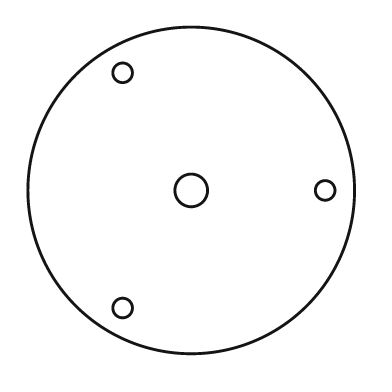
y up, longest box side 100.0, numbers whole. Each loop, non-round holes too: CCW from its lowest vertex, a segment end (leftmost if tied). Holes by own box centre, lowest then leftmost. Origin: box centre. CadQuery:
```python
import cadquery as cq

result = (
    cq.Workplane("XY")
    .moveTo(0.0, 0.0)
    .circle(50.0)
    .moveTo(-21.0, -36.0)
    .circle(3.0)
    .moveTo(0.0, 0.0)
    .circle(5.0)
    .moveTo(41.0, 0.0)
    .circle(3.0)
    .moveTo(-21.0, 36.0)
    .circle(3.0)
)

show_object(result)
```